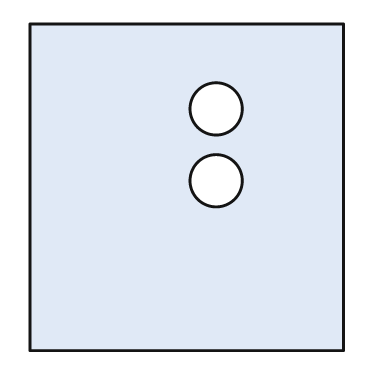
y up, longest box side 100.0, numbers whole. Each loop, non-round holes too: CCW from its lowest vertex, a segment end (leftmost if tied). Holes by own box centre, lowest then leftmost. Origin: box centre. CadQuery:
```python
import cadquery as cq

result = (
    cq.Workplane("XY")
    .moveTo(-48.0, -50.0)
    .lineTo(48.0, -50.0)
    .lineTo(48.0, 50.0)
    .lineTo(-48.0, 50.0)
    .close()
    .moveTo(9.0, 2.0)
    .circle(8.0)
    .moveTo(9.0, 24.0)
    .circle(8.0)
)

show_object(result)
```